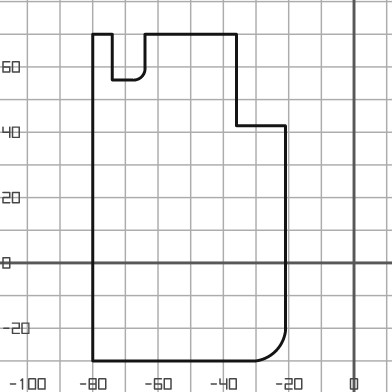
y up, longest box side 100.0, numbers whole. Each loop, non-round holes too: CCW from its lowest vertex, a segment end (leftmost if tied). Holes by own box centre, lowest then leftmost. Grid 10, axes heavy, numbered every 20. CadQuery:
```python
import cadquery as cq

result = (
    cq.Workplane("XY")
    .moveTo(-80.0, -30.0)
    .lineTo(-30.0, -30.0)
    .threePointArc((-24.0, -27.0), (-21.0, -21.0))
    .lineTo(-21.0, 42.0)
    .lineTo(-36.0, 42.0)
    .lineTo(-36.0, 70.0)
    .lineTo(-64.0, 70.0)
    .lineTo(-64.0, 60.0)
    .threePointArc((-65.0, 57.0), (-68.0, 56.0))
    .lineTo(-74.0, 56.0)
    .lineTo(-74.0, 70.0)
    .lineTo(-80.0, 70.0)
    .close()
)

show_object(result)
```